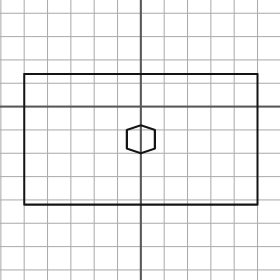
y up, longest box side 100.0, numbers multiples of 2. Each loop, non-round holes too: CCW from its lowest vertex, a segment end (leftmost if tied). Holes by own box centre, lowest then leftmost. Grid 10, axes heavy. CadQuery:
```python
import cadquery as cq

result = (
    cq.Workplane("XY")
    .moveTo(-50.0, -42.0)
    .lineTo(50.0, -42.0)
    .lineTo(50.0, 14.0)
    .lineTo(-50.0, 14.0)
    .close()
    .moveTo(0.0, -20.0)
    .lineTo(6.0, -18.0)
    .lineTo(6.0, -10.0)
    .lineTo(0.0, -8.0)
    .lineTo(-6.0, -10.0)
    .lineTo(-6.0, -18.0)
    .close()
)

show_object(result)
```